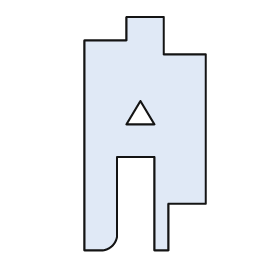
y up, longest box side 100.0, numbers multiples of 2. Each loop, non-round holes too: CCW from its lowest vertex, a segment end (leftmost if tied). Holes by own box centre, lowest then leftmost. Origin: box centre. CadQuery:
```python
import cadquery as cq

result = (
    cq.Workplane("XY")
    .moveTo(-26.0, -50.0)
    .lineTo(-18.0, -50.0)
    .threePointArc((-14.0, -48.0), (-12.0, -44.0))
    .lineTo(-12.0, -10.0)
    .lineTo(4.0, -10.0)
    .lineTo(4.0, -50.0)
    .lineTo(10.0, -50.0)
    .lineTo(10.0, -30.0)
    .lineTo(26.0, -30.0)
    .lineTo(26.0, 34.0)
    .lineTo(8.0, 34.0)
    .lineTo(8.0, 50.0)
    .lineTo(-8.0, 50.0)
    .lineTo(-8.0, 40.0)
    .lineTo(-26.0, 40.0)
    .close()
    .moveTo(-8.0, 4.0)
    .lineTo(4.0, 4.0)
    .lineTo(-2.0, 14.0)
    .close()
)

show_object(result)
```